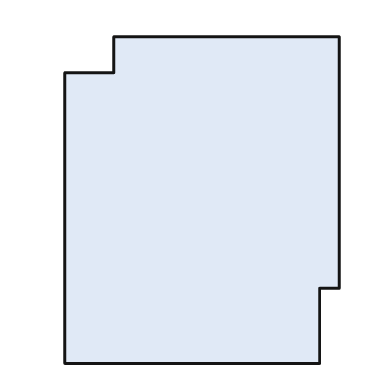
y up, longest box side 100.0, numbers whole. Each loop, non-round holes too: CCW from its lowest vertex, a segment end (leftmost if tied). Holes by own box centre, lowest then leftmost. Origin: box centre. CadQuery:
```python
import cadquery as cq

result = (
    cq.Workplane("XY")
    .moveTo(-42.0, -50.0)
    .lineTo(36.0, -50.0)
    .lineTo(36.0, -27.0)
    .lineTo(42.0, -27.0)
    .lineTo(42.0, 50.0)
    .lineTo(-27.0, 50.0)
    .lineTo(-27.0, 39.0)
    .lineTo(-42.0, 39.0)
    .close()
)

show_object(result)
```